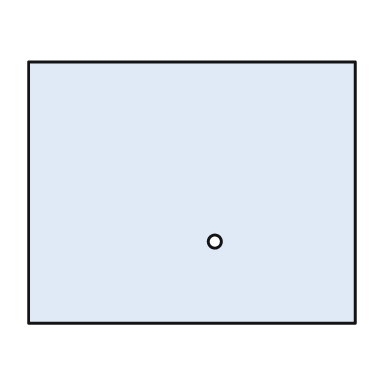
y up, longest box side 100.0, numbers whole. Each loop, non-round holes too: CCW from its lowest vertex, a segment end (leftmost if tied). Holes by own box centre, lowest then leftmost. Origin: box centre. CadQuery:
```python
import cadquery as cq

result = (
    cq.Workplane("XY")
    .moveTo(-50.0, -40.0)
    .lineTo(50.0, -40.0)
    .lineTo(50.0, 40.0)
    .lineTo(-50.0, 40.0)
    .close()
    .moveTo(7.0, -15.0)
    .circle(2.0)
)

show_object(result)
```